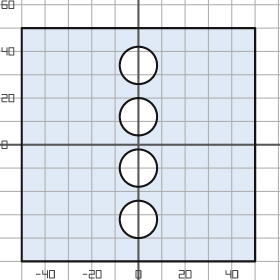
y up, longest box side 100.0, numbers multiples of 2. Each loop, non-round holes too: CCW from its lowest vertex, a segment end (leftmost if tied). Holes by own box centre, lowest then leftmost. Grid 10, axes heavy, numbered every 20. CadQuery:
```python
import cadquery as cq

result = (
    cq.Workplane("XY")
    .moveTo(-50.0, -50.0)
    .lineTo(50.0, -50.0)
    .lineTo(50.0, 50.0)
    .lineTo(-50.0, 50.0)
    .close()
    .moveTo(0.0, -32.0)
    .circle(8.0)
    .moveTo(0.0, -10.0)
    .circle(8.0)
    .moveTo(0.0, 12.0)
    .circle(8.0)
    .moveTo(0.0, 34.0)
    .circle(8.0)
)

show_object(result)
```